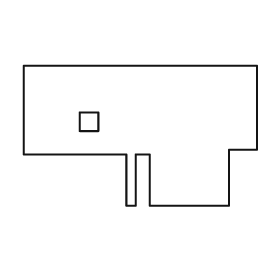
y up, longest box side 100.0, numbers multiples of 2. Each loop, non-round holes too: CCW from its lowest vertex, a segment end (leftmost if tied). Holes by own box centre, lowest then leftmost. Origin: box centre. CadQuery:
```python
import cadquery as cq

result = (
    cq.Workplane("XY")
    .moveTo(-6.0, -30.0)
    .lineTo(-2.0, -30.0)
    .lineTo(-2.0, -8.0)
    .lineTo(4.0, -8.0)
    .lineTo(4.0, -30.0)
    .lineTo(38.0, -30.0)
    .lineTo(38.0, -6.0)
    .lineTo(50.0, -6.0)
    .lineTo(50.0, 30.0)
    .lineTo(-50.0, 30.0)
    .lineTo(-50.0, -8.0)
    .lineTo(-6.0, -8.0)
    .close()
    .moveTo(-26.0, 2.0)
    .lineTo(-18.0, 2.0)
    .lineTo(-18.0, 10.0)
    .lineTo(-26.0, 10.0)
    .close()
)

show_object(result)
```